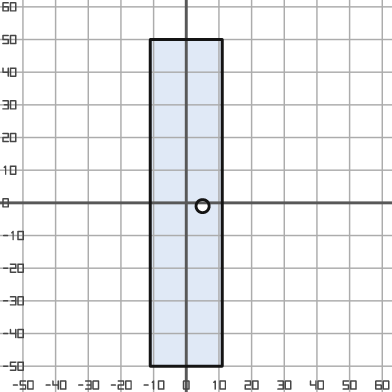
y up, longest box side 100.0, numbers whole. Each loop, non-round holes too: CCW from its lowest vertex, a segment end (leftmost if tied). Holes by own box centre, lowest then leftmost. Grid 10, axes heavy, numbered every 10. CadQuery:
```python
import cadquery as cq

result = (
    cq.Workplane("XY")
    .moveTo(-11.0, -50.0)
    .lineTo(11.0, -50.0)
    .lineTo(11.0, 50.0)
    .lineTo(-11.0, 50.0)
    .close()
    .moveTo(5.0, -1.0)
    .circle(2.0)
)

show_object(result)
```